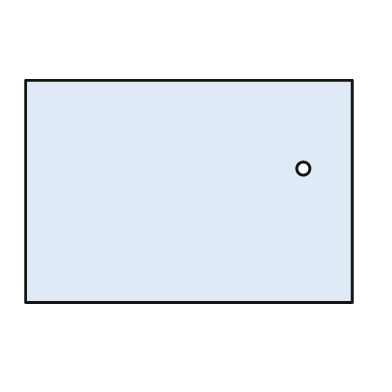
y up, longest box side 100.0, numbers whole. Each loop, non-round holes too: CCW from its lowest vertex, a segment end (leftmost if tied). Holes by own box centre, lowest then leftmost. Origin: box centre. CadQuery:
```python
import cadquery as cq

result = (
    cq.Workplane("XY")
    .moveTo(-50.0, -34.0)
    .lineTo(50.0, -34.0)
    .lineTo(50.0, 34.0)
    .lineTo(-50.0, 34.0)
    .close()
    .moveTo(35.0, 7.0)
    .circle(2.0)
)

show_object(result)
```